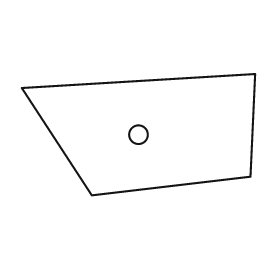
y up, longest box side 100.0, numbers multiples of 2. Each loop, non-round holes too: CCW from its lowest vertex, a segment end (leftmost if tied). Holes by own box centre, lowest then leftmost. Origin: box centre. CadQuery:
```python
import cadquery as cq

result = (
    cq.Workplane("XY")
    .moveTo(-20.0, -26.0)
    .lineTo(48.0, -18.0)
    .lineTo(50.0, 26.0)
    .lineTo(-50.0, 20.0)
    .close()
    .moveTo(0.0, 0.0)
    .circle(4.0)
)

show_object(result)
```